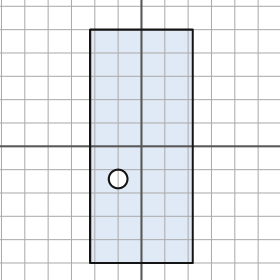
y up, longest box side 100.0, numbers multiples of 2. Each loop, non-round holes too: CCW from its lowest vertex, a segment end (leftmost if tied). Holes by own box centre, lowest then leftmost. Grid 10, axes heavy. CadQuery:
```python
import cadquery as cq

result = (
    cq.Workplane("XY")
    .moveTo(-22.0, -50.0)
    .lineTo(22.0, -50.0)
    .lineTo(22.0, 50.0)
    .lineTo(-22.0, 50.0)
    .close()
    .moveTo(-10.0, -14.0)
    .circle(4.0)
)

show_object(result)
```